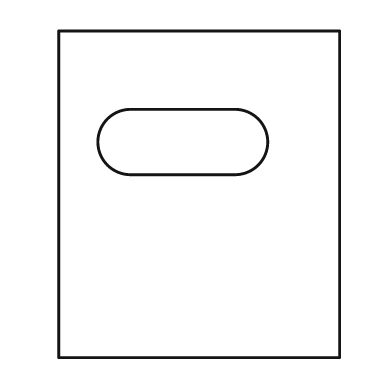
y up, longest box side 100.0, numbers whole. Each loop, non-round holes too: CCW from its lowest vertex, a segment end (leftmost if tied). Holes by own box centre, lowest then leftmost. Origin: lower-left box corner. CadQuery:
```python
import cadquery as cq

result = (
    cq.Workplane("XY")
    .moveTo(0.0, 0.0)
    .lineTo(86.0, 0.0)
    .lineTo(86.0, 100.0)
    .lineTo(0.0, 100.0)
    .close()
    .moveTo(22.0, 56.0)
    .lineTo(54.0, 56.0)
    .threePointArc((64.0, 66.0), (54.0, 76.0))
    .lineTo(22.0, 76.0)
    .threePointArc((12.0, 66.0), (22.0, 56.0))
    .close()
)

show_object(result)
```